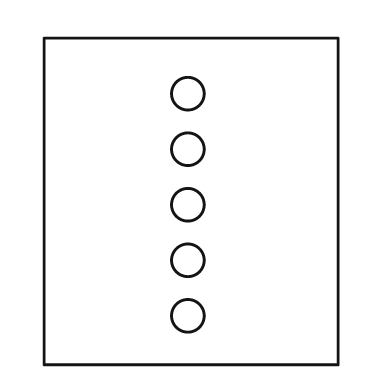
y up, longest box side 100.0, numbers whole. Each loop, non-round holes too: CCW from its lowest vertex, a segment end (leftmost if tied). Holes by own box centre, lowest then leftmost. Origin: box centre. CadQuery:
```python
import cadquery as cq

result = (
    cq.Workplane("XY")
    .moveTo(-45.0, -50.0)
    .lineTo(45.0, -50.0)
    .lineTo(45.0, 50.0)
    .lineTo(-45.0, 50.0)
    .close()
    .moveTo(-1.0, -35.0)
    .circle(5.0)
    .moveTo(-1.0, -18.0)
    .circle(5.0)
    .moveTo(-1.0, -1.0)
    .circle(5.0)
    .moveTo(-1.0, 16.0)
    .circle(5.0)
    .moveTo(-1.0, 33.0)
    .circle(5.0)
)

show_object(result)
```